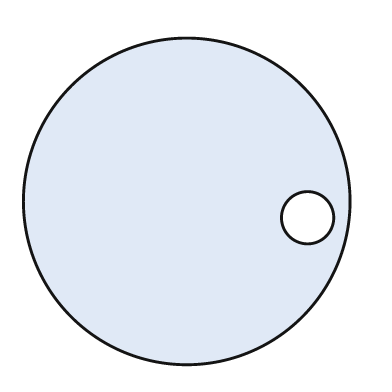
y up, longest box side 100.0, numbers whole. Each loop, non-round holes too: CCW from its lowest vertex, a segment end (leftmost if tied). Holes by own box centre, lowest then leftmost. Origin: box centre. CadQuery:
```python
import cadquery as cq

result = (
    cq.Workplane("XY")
    .moveTo(0.0, 0.0)
    .circle(50.0)
    .moveTo(37.0, -5.0)
    .circle(8.0)
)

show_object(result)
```